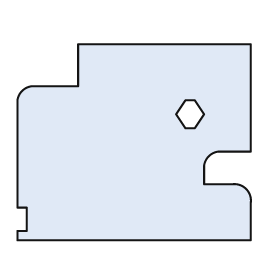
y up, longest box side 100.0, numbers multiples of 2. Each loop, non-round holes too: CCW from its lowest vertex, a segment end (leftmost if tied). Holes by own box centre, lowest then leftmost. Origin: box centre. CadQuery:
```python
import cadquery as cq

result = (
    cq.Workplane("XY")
    .moveTo(-50.0, -42.0)
    .lineTo(50.0, -42.0)
    .lineTo(50.0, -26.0)
    .threePointArc((48.0, -20.0), (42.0, -18.0))
    .lineTo(30.0, -18.0)
    .lineTo(30.0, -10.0)
    .threePointArc((32.0, -6.0), (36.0, -4.0))
    .lineTo(50.0, -4.0)
    .lineTo(50.0, 42.0)
    .lineTo(-24.0, 42.0)
    .lineTo(-24.0, 24.0)
    .lineTo(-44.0, 24.0)
    .threePointArc((-48.0, 22.0), (-50.0, 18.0))
    .lineTo(-50.0, -28.0)
    .lineTo(-46.0, -28.0)
    .lineTo(-46.0, -38.0)
    .lineTo(-50.0, -38.0)
    .close()
    .moveTo(22.0, 6.0)
    .lineTo(26.0, 6.0)
    .lineTo(30.0, 12.0)
    .lineTo(26.0, 18.0)
    .lineTo(22.0, 18.0)
    .lineTo(18.0, 12.0)
    .close()
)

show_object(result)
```